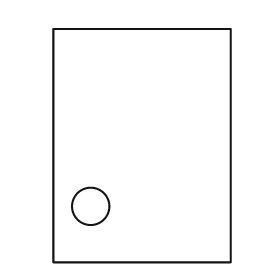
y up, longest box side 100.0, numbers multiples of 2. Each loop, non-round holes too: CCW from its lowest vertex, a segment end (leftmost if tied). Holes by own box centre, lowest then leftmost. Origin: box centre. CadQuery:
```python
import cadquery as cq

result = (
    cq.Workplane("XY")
    .moveTo(-38.0, -50.0)
    .lineTo(38.0, -50.0)
    .lineTo(38.0, 50.0)
    .lineTo(-38.0, 50.0)
    .close()
    .moveTo(-22.0, -26.0)
    .circle(8.0)
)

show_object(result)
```